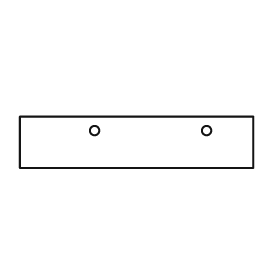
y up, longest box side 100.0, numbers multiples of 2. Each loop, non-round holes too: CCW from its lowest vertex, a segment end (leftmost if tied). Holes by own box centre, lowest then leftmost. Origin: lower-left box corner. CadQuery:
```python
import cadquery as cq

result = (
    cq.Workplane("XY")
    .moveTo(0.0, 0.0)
    .lineTo(100.0, 0.0)
    .lineTo(100.0, 22.0)
    .lineTo(0.0, 22.0)
    .close()
    .moveTo(32.0, 16.0)
    .circle(2.0)
    .moveTo(80.0, 16.0)
    .circle(2.0)
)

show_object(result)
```